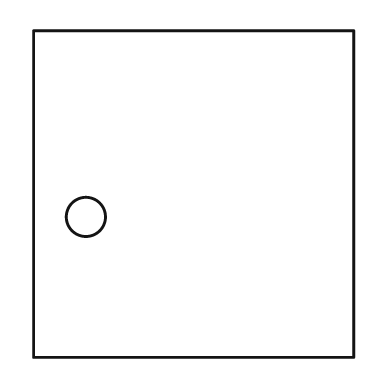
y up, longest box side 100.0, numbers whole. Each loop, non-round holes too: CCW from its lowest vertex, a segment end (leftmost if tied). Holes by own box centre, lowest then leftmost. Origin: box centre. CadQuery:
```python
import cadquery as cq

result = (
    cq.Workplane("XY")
    .moveTo(-49.0, -50.0)
    .lineTo(49.0, -50.0)
    .lineTo(49.0, 50.0)
    .lineTo(-49.0, 50.0)
    .close()
    .moveTo(-33.0, -7.0)
    .circle(6.0)
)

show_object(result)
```